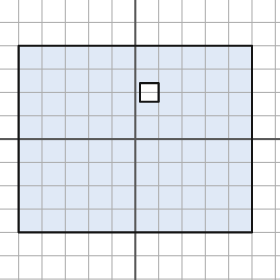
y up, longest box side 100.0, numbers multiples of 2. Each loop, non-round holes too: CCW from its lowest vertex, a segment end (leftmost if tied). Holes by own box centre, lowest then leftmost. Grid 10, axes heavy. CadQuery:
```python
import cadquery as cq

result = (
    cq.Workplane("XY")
    .moveTo(-50.0, -40.0)
    .lineTo(50.0, -40.0)
    .lineTo(50.0, 40.0)
    .lineTo(-50.0, 40.0)
    .close()
    .moveTo(2.0, 16.0)
    .lineTo(10.0, 16.0)
    .lineTo(10.0, 24.0)
    .lineTo(2.0, 24.0)
    .close()
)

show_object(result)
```